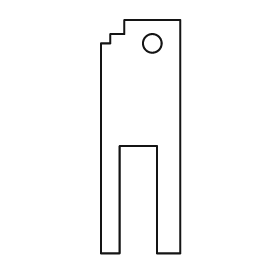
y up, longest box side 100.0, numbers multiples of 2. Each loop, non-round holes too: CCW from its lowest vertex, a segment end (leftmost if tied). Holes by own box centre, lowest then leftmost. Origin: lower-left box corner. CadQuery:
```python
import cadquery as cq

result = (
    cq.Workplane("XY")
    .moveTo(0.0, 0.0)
    .lineTo(8.0, 0.0)
    .lineTo(8.0, 46.0)
    .lineTo(24.0, 46.0)
    .lineTo(24.0, 0.0)
    .lineTo(34.0, 0.0)
    .lineTo(34.0, 100.0)
    .lineTo(10.0, 100.0)
    .lineTo(10.0, 94.0)
    .lineTo(4.0, 94.0)
    .lineTo(4.0, 90.0)
    .lineTo(0.0, 90.0)
    .close()
    .moveTo(22.0, 90.0)
    .circle(4.0)
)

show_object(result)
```